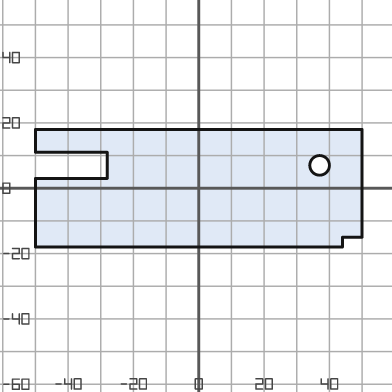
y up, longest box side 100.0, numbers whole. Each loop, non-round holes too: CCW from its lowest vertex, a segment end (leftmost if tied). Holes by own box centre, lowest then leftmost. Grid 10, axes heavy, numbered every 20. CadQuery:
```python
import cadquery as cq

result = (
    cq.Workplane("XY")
    .moveTo(-50.0, -18.0)
    .lineTo(44.0, -18.0)
    .lineTo(44.0, -15.0)
    .lineTo(50.0, -15.0)
    .lineTo(50.0, 18.0)
    .lineTo(-50.0, 18.0)
    .lineTo(-50.0, 11.0)
    .lineTo(-28.0, 11.0)
    .lineTo(-28.0, 3.0)
    .lineTo(-50.0, 3.0)
    .close()
    .moveTo(37.0, 7.0)
    .circle(3.0)
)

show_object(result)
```